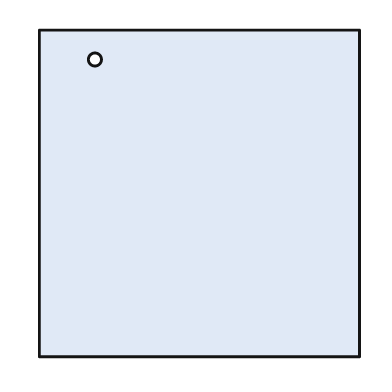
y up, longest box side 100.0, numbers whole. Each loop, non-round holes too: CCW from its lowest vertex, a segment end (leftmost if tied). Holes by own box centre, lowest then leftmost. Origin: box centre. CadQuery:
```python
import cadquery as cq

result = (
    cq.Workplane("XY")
    .moveTo(-49.0, -50.0)
    .lineTo(49.0, -50.0)
    .lineTo(49.0, 50.0)
    .lineTo(-49.0, 50.0)
    .close()
    .moveTo(-32.0, 41.0)
    .circle(2.0)
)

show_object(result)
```